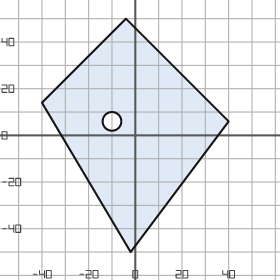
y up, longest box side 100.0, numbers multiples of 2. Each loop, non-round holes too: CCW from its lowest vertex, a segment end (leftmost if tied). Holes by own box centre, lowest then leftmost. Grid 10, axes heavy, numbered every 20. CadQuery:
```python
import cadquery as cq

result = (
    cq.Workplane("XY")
    .moveTo(-2.0, -50.0)
    .lineTo(40.0, 6.0)
    .lineTo(-4.0, 50.0)
    .lineTo(-40.0, 14.0)
    .close()
    .moveTo(-10.0, 6.0)
    .circle(4.0)
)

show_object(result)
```